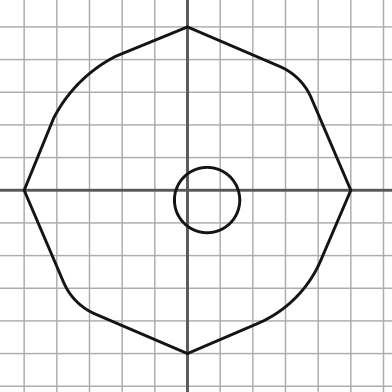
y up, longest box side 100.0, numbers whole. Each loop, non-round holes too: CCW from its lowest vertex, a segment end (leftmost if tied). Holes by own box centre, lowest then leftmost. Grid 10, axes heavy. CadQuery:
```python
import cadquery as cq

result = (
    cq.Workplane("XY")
    .moveTo(0.0, -50.0)
    .lineTo(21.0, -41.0)
    .threePointArc((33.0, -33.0), (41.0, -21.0))
    .lineTo(50.0, 0.0)
    .lineTo(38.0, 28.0)
    .threePointArc((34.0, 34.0), (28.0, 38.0))
    .lineTo(0.0, 50.0)
    .lineTo(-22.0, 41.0)
    .threePointArc((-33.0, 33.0), (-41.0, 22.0))
    .lineTo(-50.0, 0.0)
    .lineTo(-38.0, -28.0)
    .threePointArc((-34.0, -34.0), (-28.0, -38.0))
    .close()
    .moveTo(6.0, -3.0)
    .circle(10.0)
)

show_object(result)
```